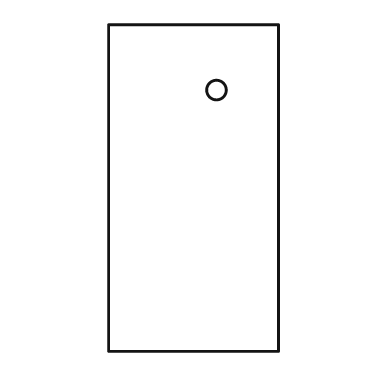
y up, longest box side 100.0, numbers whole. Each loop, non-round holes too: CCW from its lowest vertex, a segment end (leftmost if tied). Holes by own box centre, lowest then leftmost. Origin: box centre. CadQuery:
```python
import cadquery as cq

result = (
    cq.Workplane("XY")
    .moveTo(-26.0, -50.0)
    .lineTo(26.0, -50.0)
    .lineTo(26.0, 50.0)
    .lineTo(-26.0, 50.0)
    .close()
    .moveTo(7.0, 30.0)
    .circle(3.0)
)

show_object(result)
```